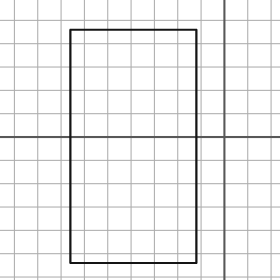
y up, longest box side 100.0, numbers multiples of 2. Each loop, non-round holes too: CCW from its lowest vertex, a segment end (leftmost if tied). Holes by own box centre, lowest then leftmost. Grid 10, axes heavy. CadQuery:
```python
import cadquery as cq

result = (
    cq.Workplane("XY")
    .moveTo(-66.0, -54.0)
    .lineTo(-12.0, -54.0)
    .lineTo(-12.0, 46.0)
    .lineTo(-66.0, 46.0)
    .close()
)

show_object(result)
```